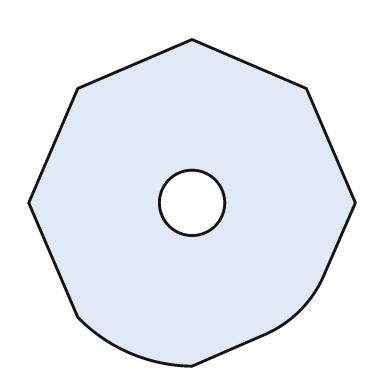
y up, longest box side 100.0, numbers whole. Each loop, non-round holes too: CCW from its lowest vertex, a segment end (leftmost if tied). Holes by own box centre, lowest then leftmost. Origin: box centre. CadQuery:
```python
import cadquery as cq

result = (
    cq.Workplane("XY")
    .moveTo(0.0, -50.0)
    .lineTo(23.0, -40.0)
    .threePointArc((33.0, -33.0), (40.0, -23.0))
    .lineTo(50.0, 0.0)
    .lineTo(35.0, 35.0)
    .lineTo(0.0, 50.0)
    .lineTo(-35.0, 35.0)
    .lineTo(-50.0, 0.0)
    .lineTo(-35.0, -35.0)
    .threePointArc((-19.0, -46.0), (0.0, -50.0))
    .close()
    .moveTo(0.0, 0.0)
    .circle(10.0)
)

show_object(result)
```